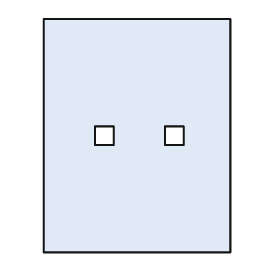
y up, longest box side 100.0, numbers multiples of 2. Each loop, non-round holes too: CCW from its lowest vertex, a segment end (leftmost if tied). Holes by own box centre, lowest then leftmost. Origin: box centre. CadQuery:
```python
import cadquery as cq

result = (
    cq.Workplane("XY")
    .moveTo(-40.0, -50.0)
    .lineTo(40.0, -50.0)
    .lineTo(40.0, 50.0)
    .lineTo(-40.0, 50.0)
    .close()
    .moveTo(-18.0, -4.0)
    .lineTo(-10.0, -4.0)
    .lineTo(-10.0, 4.0)
    .lineTo(-18.0, 4.0)
    .close()
    .moveTo(12.0, -4.0)
    .lineTo(20.0, -4.0)
    .lineTo(20.0, 4.0)
    .lineTo(12.0, 4.0)
    .close()
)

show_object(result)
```